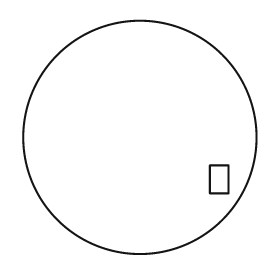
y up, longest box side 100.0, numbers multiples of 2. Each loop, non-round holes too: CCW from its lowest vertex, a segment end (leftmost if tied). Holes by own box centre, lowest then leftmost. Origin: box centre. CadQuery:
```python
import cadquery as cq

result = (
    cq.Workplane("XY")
    .moveTo(0.0, 0.0)
    .circle(50.0)
    .moveTo(30.0, -24.0)
    .lineTo(38.0, -24.0)
    .lineTo(38.0, -12.0)
    .lineTo(30.0, -12.0)
    .close()
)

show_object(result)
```